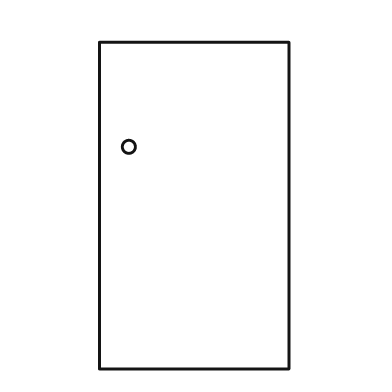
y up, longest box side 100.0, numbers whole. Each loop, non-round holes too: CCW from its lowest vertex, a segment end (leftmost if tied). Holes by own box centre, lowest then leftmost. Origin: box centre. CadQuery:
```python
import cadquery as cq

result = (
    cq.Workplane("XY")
    .moveTo(-29.0, -50.0)
    .lineTo(29.0, -50.0)
    .lineTo(29.0, 50.0)
    .lineTo(-29.0, 50.0)
    .close()
    .moveTo(-20.0, 18.0)
    .circle(2.0)
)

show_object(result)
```